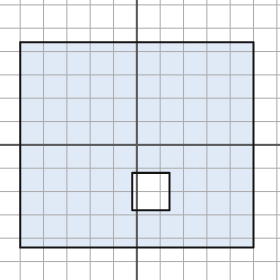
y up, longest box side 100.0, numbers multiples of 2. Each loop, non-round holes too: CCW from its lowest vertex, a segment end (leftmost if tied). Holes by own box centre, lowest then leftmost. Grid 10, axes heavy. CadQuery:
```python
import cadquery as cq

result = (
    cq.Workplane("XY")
    .moveTo(-50.0, -44.0)
    .lineTo(50.0, -44.0)
    .lineTo(50.0, 44.0)
    .lineTo(-50.0, 44.0)
    .close()
    .moveTo(-2.0, -28.0)
    .lineTo(14.0, -28.0)
    .lineTo(14.0, -12.0)
    .lineTo(-2.0, -12.0)
    .close()
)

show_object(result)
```